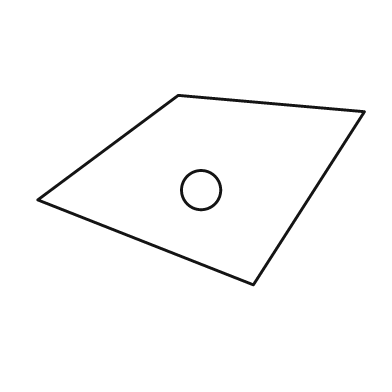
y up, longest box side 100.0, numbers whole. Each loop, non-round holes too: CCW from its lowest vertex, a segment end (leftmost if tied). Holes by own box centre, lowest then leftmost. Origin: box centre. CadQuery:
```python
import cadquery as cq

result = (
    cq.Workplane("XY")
    .moveTo(16.0, -29.0)
    .lineTo(50.0, 24.0)
    .lineTo(-7.0, 29.0)
    .lineTo(-50.0, -3.0)
    .close()
    .moveTo(0.0, 0.0)
    .circle(6.0)
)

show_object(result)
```